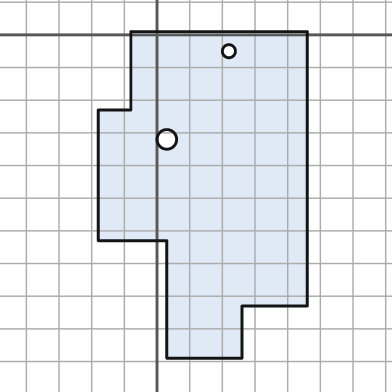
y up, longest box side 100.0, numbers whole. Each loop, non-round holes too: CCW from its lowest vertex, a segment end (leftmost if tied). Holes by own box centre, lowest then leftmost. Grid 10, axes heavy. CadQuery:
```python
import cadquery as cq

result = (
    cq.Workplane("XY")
    .moveTo(3.0, -99.0)
    .lineTo(26.0, -99.0)
    .lineTo(26.0, -83.0)
    .lineTo(46.0, -83.0)
    .lineTo(46.0, 1.0)
    .lineTo(-8.0, 1.0)
    .lineTo(-8.0, -23.0)
    .lineTo(-18.0, -23.0)
    .lineTo(-18.0, -63.0)
    .lineTo(3.0, -63.0)
    .close()
    .moveTo(3.0, -32.0)
    .circle(3.0)
    .moveTo(22.0, -5.0)
    .circle(2.0)
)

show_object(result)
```